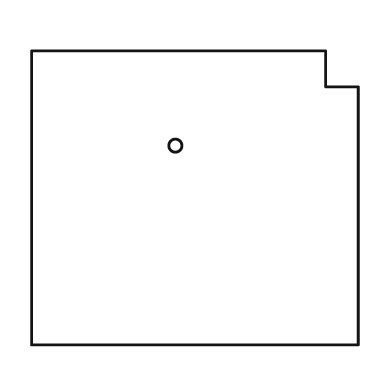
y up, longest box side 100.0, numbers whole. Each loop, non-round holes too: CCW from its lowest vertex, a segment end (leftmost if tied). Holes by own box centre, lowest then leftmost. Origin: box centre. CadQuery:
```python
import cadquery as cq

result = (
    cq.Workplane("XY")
    .moveTo(-50.0, -45.0)
    .lineTo(50.0, -45.0)
    .lineTo(50.0, 34.0)
    .lineTo(40.0, 34.0)
    .lineTo(40.0, 45.0)
    .lineTo(-50.0, 45.0)
    .close()
    .moveTo(-6.0, 16.0)
    .circle(2.0)
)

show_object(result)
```